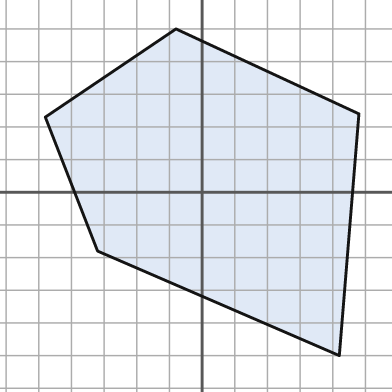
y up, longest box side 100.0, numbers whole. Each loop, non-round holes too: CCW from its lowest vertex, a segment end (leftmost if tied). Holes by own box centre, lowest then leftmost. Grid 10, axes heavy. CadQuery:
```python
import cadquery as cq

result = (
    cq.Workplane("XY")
    .moveTo(42.0, -50.0)
    .lineTo(48.0, 24.0)
    .lineTo(-8.0, 50.0)
    .lineTo(-48.0, 23.0)
    .lineTo(-32.0, -18.0)
    .close()
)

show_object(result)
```